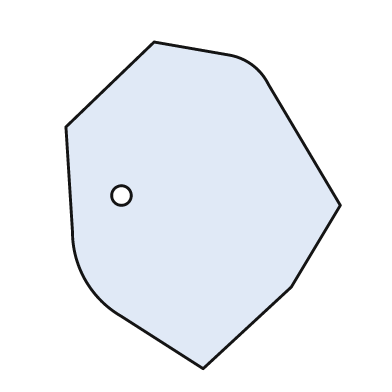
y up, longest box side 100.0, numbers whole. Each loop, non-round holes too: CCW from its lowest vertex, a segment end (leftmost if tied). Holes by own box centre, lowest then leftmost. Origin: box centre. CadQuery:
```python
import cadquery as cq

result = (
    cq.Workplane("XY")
    .moveTo(0.0, -50.0)
    .lineTo(27.0, -25.0)
    .lineTo(42.0, 0.0)
    .lineTo(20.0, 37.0)
    .threePointArc((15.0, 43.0), (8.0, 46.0))
    .lineTo(-15.0, 50.0)
    .lineTo(-42.0, 24.0)
    .lineTo(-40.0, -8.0)
    .threePointArc((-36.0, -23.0), (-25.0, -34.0))
    .close()
    .moveTo(-25.0, 3.0)
    .circle(3.0)
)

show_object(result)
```